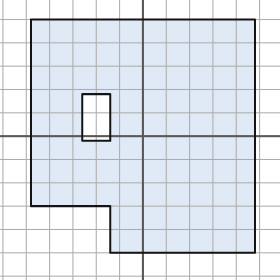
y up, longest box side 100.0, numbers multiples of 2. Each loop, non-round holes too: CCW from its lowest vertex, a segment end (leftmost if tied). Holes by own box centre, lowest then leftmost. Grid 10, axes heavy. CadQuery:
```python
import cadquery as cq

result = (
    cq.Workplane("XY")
    .moveTo(-14.0, -50.0)
    .lineTo(48.0, -50.0)
    .lineTo(48.0, 50.0)
    .lineTo(-48.0, 50.0)
    .lineTo(-48.0, -30.0)
    .lineTo(-14.0, -30.0)
    .close()
    .moveTo(-26.0, -2.0)
    .lineTo(-14.0, -2.0)
    .lineTo(-14.0, 18.0)
    .lineTo(-26.0, 18.0)
    .close()
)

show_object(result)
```